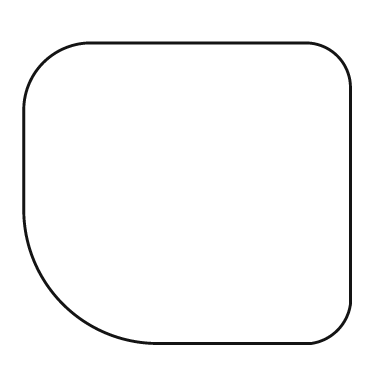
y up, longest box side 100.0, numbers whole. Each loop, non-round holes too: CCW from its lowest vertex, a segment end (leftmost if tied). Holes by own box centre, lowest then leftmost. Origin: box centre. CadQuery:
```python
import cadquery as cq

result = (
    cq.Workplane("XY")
    .moveTo(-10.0, -46.0)
    .lineTo(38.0, -46.0)
    .threePointArc((46.0, -42.0), (50.0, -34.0))
    .lineTo(50.0, 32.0)
    .threePointArc((46.0, 42.0), (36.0, 46.0))
    .lineTo(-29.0, 46.0)
    .threePointArc((-44.0, 40.0), (-50.0, 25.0))
    .lineTo(-50.0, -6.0)
    .threePointArc((-38.0, -34.0), (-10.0, -46.0))
    .close()
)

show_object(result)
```